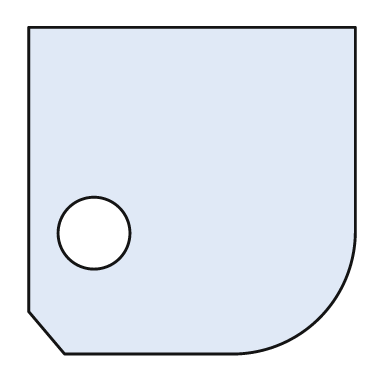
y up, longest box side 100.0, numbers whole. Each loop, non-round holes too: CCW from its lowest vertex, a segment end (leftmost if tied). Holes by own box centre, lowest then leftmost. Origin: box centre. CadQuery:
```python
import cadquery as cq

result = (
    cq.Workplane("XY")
    .moveTo(-39.0, -50.0)
    .lineTo(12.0, -50.0)
    .threePointArc((39.0, -39.0), (50.0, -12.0))
    .lineTo(50.0, 50.0)
    .lineTo(-50.0, 50.0)
    .lineTo(-50.0, -37.0)
    .close()
    .moveTo(-30.0, -13.0)
    .circle(11.0)
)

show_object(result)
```